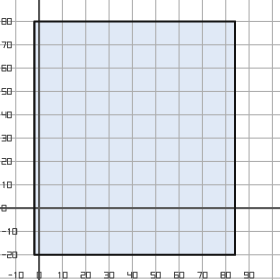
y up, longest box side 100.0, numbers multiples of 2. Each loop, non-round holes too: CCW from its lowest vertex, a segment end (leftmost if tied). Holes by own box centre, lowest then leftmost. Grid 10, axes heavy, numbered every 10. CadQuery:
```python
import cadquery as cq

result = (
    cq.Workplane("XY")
    .moveTo(-2.0, -20.0)
    .lineTo(84.0, -20.0)
    .lineTo(84.0, 80.0)
    .lineTo(-2.0, 80.0)
    .close()
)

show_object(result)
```